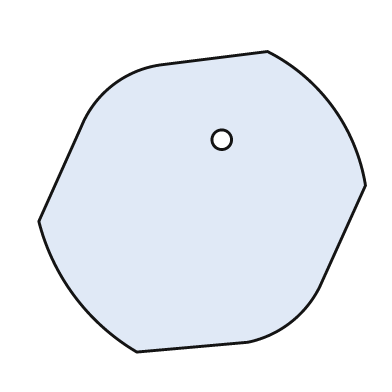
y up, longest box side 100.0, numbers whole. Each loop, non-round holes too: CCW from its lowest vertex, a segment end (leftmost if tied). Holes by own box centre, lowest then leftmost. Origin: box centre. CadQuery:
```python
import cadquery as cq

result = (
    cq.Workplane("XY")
    .moveTo(-20.0, -46.0)
    .lineTo(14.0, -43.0)
    .threePointArc((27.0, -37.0), (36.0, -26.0))
    .lineTo(50.0, 5.0)
    .threePointArc((40.0, 29.0), (20.0, 46.0))
    .lineTo(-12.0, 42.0)
    .threePointArc((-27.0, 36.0), (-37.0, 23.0))
    .lineTo(-50.0, -6.0)
    .threePointArc((-39.0, -29.0), (-20.0, -46.0))
    .close()
    .moveTo(6.0, 19.0)
    .circle(3.0)
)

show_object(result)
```